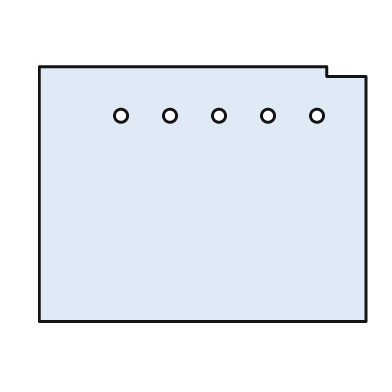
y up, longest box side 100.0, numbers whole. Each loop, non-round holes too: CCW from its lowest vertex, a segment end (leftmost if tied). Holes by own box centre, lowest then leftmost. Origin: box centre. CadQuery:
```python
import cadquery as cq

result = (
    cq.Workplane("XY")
    .moveTo(-50.0, -39.0)
    .lineTo(50.0, -39.0)
    .lineTo(50.0, 36.0)
    .lineTo(38.0, 36.0)
    .lineTo(38.0, 39.0)
    .lineTo(-50.0, 39.0)
    .close()
    .moveTo(-25.0, 24.0)
    .circle(2.0)
    .moveTo(-10.0, 24.0)
    .circle(2.0)
    .moveTo(5.0, 24.0)
    .circle(2.0)
    .moveTo(20.0, 24.0)
    .circle(2.0)
    .moveTo(35.0, 24.0)
    .circle(2.0)
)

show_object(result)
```